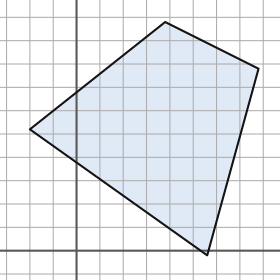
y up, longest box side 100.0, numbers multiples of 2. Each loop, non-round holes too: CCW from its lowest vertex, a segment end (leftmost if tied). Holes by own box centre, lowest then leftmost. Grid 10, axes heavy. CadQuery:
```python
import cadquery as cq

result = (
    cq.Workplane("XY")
    .moveTo(56.0, -2.0)
    .lineTo(78.0, 78.0)
    .lineTo(38.0, 98.0)
    .lineTo(-20.0, 52.0)
    .close()
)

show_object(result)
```